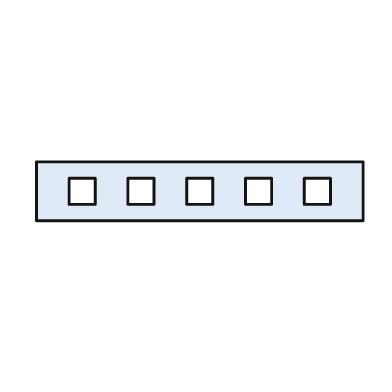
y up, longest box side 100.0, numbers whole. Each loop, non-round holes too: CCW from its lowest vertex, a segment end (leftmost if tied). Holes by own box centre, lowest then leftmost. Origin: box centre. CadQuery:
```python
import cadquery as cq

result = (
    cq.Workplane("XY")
    .moveTo(-50.0, -9.0)
    .lineTo(50.0, -9.0)
    .lineTo(50.0, 9.0)
    .lineTo(-50.0, 9.0)
    .close()
    .moveTo(-40.0, -4.0)
    .lineTo(-32.0, -4.0)
    .lineTo(-32.0, 4.0)
    .lineTo(-40.0, 4.0)
    .close()
    .moveTo(-22.0, -4.0)
    .lineTo(-14.0, -4.0)
    .lineTo(-14.0, 4.0)
    .lineTo(-22.0, 4.0)
    .close()
    .moveTo(-4.0, -4.0)
    .lineTo(4.0, -4.0)
    .lineTo(4.0, 4.0)
    .lineTo(-4.0, 4.0)
    .close()
    .moveTo(14.0, -4.0)
    .lineTo(22.0, -4.0)
    .lineTo(22.0, 4.0)
    .lineTo(14.0, 4.0)
    .close()
    .moveTo(32.0, -4.0)
    .lineTo(40.0, -4.0)
    .lineTo(40.0, 4.0)
    .lineTo(32.0, 4.0)
    .close()
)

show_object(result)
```